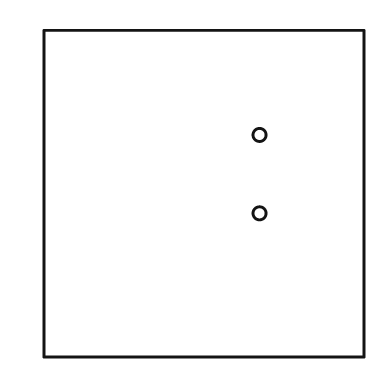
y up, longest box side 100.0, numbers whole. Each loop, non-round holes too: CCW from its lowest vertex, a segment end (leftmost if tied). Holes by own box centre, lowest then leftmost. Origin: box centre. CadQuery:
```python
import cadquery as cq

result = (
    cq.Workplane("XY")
    .moveTo(-49.0, -50.0)
    .lineTo(49.0, -50.0)
    .lineTo(49.0, 50.0)
    .lineTo(-49.0, 50.0)
    .close()
    .moveTo(17.0, -6.0)
    .circle(2.0)
    .moveTo(17.0, 18.0)
    .circle(2.0)
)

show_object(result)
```